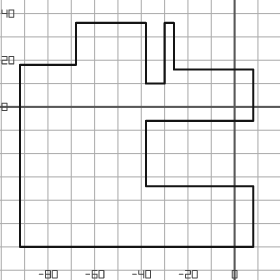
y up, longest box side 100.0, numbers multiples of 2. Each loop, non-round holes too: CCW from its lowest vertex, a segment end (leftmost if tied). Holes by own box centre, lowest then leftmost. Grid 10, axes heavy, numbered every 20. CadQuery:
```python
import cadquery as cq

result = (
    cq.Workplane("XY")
    .moveTo(-92.0, -60.0)
    .lineTo(8.0, -60.0)
    .lineTo(8.0, -34.0)
    .lineTo(-38.0, -34.0)
    .lineTo(-38.0, -6.0)
    .lineTo(8.0, -6.0)
    .lineTo(8.0, 16.0)
    .lineTo(-26.0, 16.0)
    .lineTo(-26.0, 36.0)
    .lineTo(-30.0, 36.0)
    .lineTo(-30.0, 10.0)
    .lineTo(-38.0, 10.0)
    .lineTo(-38.0, 36.0)
    .lineTo(-68.0, 36.0)
    .lineTo(-68.0, 18.0)
    .lineTo(-92.0, 18.0)
    .close()
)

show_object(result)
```